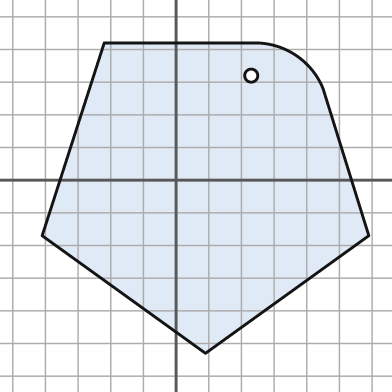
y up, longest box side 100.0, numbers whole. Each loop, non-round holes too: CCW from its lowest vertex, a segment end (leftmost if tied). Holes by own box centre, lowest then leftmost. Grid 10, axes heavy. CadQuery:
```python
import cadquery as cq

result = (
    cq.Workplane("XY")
    .moveTo(9.0, -53.0)
    .lineTo(59.0, -17.0)
    .lineTo(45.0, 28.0)
    .threePointArc((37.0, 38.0), (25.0, 42.0))
    .lineTo(-22.0, 42.0)
    .lineTo(-41.0, -17.0)
    .close()
    .moveTo(23.0, 32.0)
    .circle(2.0)
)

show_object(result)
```